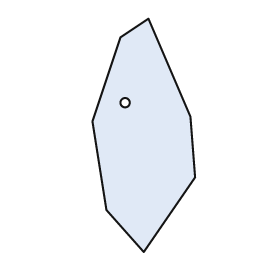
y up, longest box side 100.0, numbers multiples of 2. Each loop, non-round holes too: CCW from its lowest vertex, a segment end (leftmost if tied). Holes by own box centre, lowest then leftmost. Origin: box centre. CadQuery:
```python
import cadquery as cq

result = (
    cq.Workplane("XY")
    .moveTo(0.0, -50.0)
    .lineTo(22.0, -18.0)
    .lineTo(20.0, 8.0)
    .lineTo(2.0, 50.0)
    .lineTo(-10.0, 42.0)
    .lineTo(-22.0, 6.0)
    .lineTo(-16.0, -32.0)
    .close()
    .moveTo(-8.0, 14.0)
    .circle(2.0)
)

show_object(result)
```